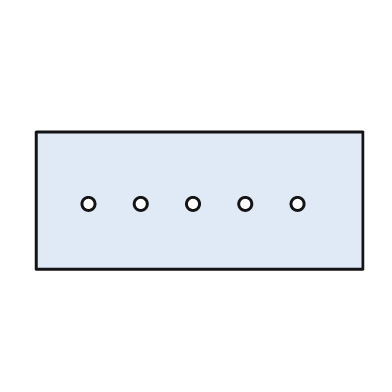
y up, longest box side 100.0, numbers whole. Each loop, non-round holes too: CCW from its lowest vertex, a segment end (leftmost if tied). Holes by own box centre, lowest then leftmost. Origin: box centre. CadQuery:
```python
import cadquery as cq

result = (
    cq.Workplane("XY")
    .moveTo(-50.0, -21.0)
    .lineTo(50.0, -21.0)
    .lineTo(50.0, 21.0)
    .lineTo(-50.0, 21.0)
    .close()
    .moveTo(-34.0, -1.0)
    .circle(2.0)
    .moveTo(-18.0, -1.0)
    .circle(2.0)
    .moveTo(-2.0, -1.0)
    .circle(2.0)
    .moveTo(14.0, -1.0)
    .circle(2.0)
    .moveTo(30.0, -1.0)
    .circle(2.0)
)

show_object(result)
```